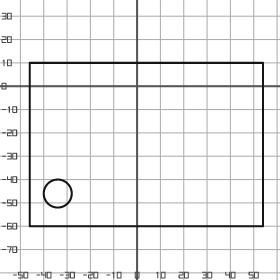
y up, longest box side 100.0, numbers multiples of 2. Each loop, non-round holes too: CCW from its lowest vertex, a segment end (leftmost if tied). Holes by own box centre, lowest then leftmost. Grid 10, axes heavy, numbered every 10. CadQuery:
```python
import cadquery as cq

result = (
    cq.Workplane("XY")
    .moveTo(-46.0, -60.0)
    .lineTo(54.0, -60.0)
    .lineTo(54.0, 10.0)
    .lineTo(-46.0, 10.0)
    .close()
    .moveTo(-34.0, -46.0)
    .circle(6.0)
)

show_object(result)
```